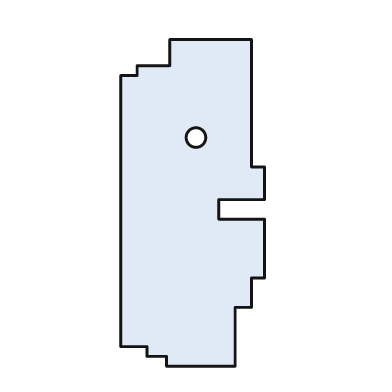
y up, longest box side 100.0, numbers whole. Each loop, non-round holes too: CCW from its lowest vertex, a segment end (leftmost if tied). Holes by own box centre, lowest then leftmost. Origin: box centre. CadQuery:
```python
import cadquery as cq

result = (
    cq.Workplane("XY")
    .moveTo(-8.0, -50.0)
    .lineTo(13.0, -50.0)
    .lineTo(13.0, -32.0)
    .lineTo(18.0, -32.0)
    .lineTo(18.0, -23.0)
    .lineTo(22.0, -23.0)
    .lineTo(22.0, -5.0)
    .lineTo(8.0, -5.0)
    .lineTo(8.0, 1.0)
    .lineTo(22.0, 1.0)
    .lineTo(22.0, 11.0)
    .lineTo(18.0, 11.0)
    .lineTo(18.0, 50.0)
    .lineTo(-7.0, 50.0)
    .lineTo(-7.0, 42.0)
    .lineTo(-17.0, 42.0)
    .lineTo(-17.0, 39.0)
    .lineTo(-22.0, 39.0)
    .lineTo(-22.0, -44.0)
    .lineTo(-14.0, -44.0)
    .lineTo(-14.0, -47.0)
    .lineTo(-8.0, -47.0)
    .close()
    .moveTo(1.0, 20.0)
    .circle(3.0)
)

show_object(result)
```